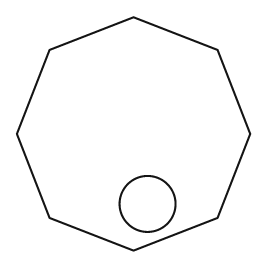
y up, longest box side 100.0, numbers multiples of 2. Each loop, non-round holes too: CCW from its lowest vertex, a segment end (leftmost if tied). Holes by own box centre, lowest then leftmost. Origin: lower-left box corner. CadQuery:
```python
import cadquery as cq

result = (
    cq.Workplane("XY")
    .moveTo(50.0, 0.0)
    .lineTo(86.0, 14.0)
    .lineTo(100.0, 50.0)
    .lineTo(86.0, 86.0)
    .lineTo(50.0, 100.0)
    .lineTo(14.0, 86.0)
    .lineTo(0.0, 50.0)
    .lineTo(14.0, 14.0)
    .close()
    .moveTo(56.0, 20.0)
    .circle(12.0)
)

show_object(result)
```